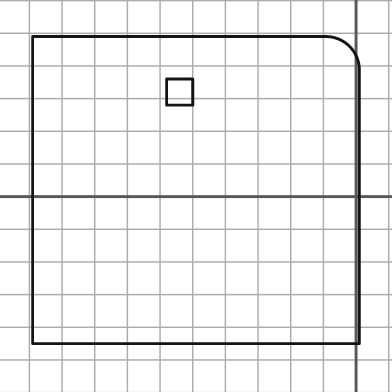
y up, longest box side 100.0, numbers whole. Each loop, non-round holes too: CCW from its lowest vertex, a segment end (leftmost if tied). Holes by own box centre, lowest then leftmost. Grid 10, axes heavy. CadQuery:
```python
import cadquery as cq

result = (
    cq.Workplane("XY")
    .moveTo(-99.0, -45.0)
    .lineTo(1.0, -45.0)
    .lineTo(1.0, 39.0)
    .threePointArc((-2.0, 46.0), (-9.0, 49.0))
    .lineTo(-99.0, 49.0)
    .close()
    .moveTo(-58.0, 28.0)
    .lineTo(-50.0, 28.0)
    .lineTo(-50.0, 36.0)
    .lineTo(-58.0, 36.0)
    .close()
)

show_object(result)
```